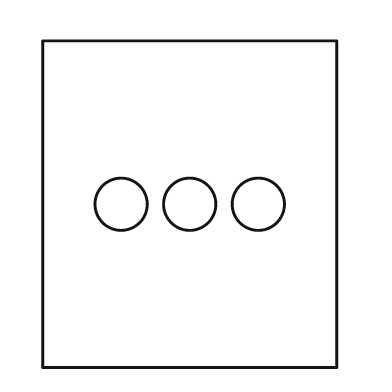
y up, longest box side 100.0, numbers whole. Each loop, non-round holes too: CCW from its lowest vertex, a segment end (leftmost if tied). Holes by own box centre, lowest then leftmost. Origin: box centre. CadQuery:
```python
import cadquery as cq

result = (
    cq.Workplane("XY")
    .moveTo(-45.0, -50.0)
    .lineTo(45.0, -50.0)
    .lineTo(45.0, 50.0)
    .lineTo(-45.0, 50.0)
    .close()
    .moveTo(-21.0, 0.0)
    .circle(8.0)
    .moveTo(0.0, 0.0)
    .circle(8.0)
    .moveTo(21.0, 0.0)
    .circle(8.0)
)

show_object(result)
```